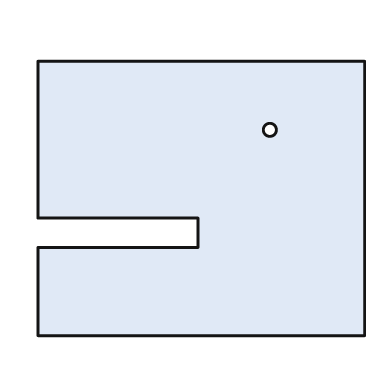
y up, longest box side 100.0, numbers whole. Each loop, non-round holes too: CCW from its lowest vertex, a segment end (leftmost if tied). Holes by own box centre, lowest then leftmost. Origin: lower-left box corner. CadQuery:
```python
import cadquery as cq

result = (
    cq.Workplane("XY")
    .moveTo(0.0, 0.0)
    .lineTo(100.0, 0.0)
    .lineTo(100.0, 84.0)
    .lineTo(0.0, 84.0)
    .lineTo(0.0, 36.0)
    .lineTo(49.0, 36.0)
    .lineTo(49.0, 27.0)
    .lineTo(0.0, 27.0)
    .close()
    .moveTo(71.0, 63.0)
    .circle(2.0)
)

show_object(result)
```